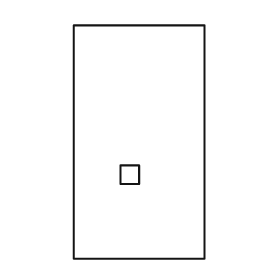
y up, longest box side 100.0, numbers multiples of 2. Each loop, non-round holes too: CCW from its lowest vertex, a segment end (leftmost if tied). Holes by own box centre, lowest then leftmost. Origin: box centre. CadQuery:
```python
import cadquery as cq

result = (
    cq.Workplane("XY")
    .moveTo(-28.0, -50.0)
    .lineTo(28.0, -50.0)
    .lineTo(28.0, 50.0)
    .lineTo(-28.0, 50.0)
    .close()
    .moveTo(-8.0, -18.0)
    .lineTo(0.0, -18.0)
    .lineTo(0.0, -10.0)
    .lineTo(-8.0, -10.0)
    .close()
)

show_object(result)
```